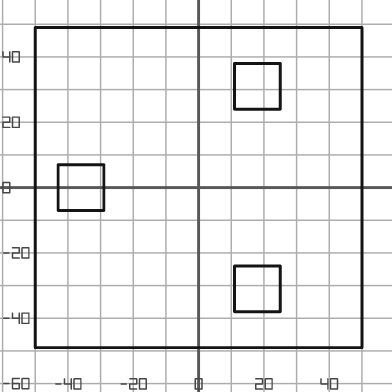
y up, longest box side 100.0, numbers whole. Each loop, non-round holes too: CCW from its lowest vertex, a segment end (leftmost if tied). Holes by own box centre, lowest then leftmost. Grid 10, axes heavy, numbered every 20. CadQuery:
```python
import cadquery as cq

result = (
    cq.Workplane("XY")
    .moveTo(-50.0, -49.0)
    .lineTo(50.0, -49.0)
    .lineTo(50.0, 49.0)
    .lineTo(-50.0, 49.0)
    .close()
    .moveTo(11.0, -38.0)
    .lineTo(25.0, -38.0)
    .lineTo(25.0, -24.0)
    .lineTo(11.0, -24.0)
    .close()
    .moveTo(-43.0, -7.0)
    .lineTo(-29.0, -7.0)
    .lineTo(-29.0, 7.0)
    .lineTo(-43.0, 7.0)
    .close()
    .moveTo(11.0, 24.0)
    .lineTo(25.0, 24.0)
    .lineTo(25.0, 38.0)
    .lineTo(11.0, 38.0)
    .close()
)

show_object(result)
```